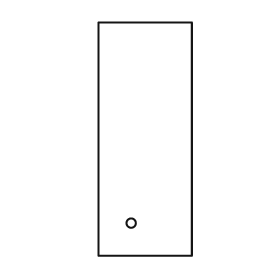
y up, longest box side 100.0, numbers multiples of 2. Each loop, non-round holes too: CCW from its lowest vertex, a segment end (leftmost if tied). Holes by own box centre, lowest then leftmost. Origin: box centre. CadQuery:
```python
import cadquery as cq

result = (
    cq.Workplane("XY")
    .moveTo(-20.0, -50.0)
    .lineTo(20.0, -50.0)
    .lineTo(20.0, 50.0)
    .lineTo(-20.0, 50.0)
    .close()
    .moveTo(-6.0, -36.0)
    .circle(2.0)
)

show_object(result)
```